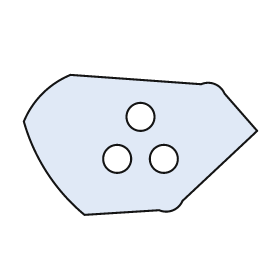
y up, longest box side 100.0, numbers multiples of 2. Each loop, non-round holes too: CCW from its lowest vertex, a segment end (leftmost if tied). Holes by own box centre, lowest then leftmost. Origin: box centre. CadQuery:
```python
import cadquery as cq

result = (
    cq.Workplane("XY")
    .moveTo(-24.0, -30.0)
    .lineTo(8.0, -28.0)
    .threePointArc((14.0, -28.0), (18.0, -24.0))
    .lineTo(50.0, 6.0)
    .lineTo(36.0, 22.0)
    .threePointArc((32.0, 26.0), (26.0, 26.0))
    .lineTo(-30.0, 30.0)
    .threePointArc((-42.0, 22.0), (-50.0, 10.0))
    .threePointArc((-40.0, -12.0), (-24.0, -30.0))
    .close()
    .moveTo(-10.0, -6.0)
    .circle(6.0)
    .moveTo(10.0, -6.0)
    .circle(6.0)
    .moveTo(0.0, 12.0)
    .circle(6.0)
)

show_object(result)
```